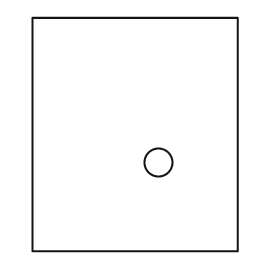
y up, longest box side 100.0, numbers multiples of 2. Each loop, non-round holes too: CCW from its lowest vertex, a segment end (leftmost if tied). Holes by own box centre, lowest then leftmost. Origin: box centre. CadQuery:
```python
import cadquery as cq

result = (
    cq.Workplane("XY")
    .moveTo(-44.0, -50.0)
    .lineTo(44.0, -50.0)
    .lineTo(44.0, 50.0)
    .lineTo(-44.0, 50.0)
    .close()
    .moveTo(10.0, -12.0)
    .circle(6.0)
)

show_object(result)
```